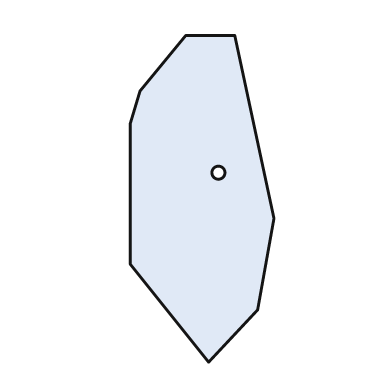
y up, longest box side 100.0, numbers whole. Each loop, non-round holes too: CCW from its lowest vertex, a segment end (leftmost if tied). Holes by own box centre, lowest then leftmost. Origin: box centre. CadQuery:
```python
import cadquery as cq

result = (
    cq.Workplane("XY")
    .moveTo(2.0, -50.0)
    .lineTo(17.0, -34.0)
    .lineTo(22.0, -6.0)
    .lineTo(10.0, 50.0)
    .lineTo(-5.0, 50.0)
    .lineTo(-19.0, 33.0)
    .lineTo(-22.0, 23.0)
    .lineTo(-22.0, -20.0)
    .close()
    .moveTo(5.0, 8.0)
    .circle(2.0)
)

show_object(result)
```